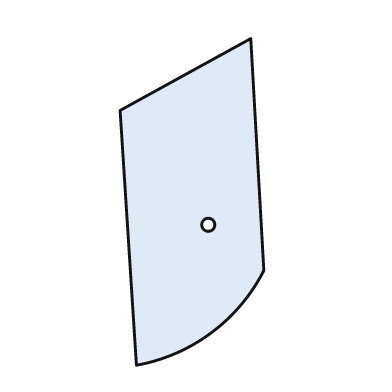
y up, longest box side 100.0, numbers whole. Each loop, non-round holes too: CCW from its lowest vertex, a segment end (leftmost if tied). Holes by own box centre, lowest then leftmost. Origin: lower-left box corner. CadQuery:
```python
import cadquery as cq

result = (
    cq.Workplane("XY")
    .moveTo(5.0, 0.0)
    .threePointArc((28.0, 10.0), (44.0, 29.0))
    .lineTo(40.0, 100.0)
    .lineTo(0.0, 78.0)
    .close()
    .moveTo(27.0, 43.0)
    .circle(2.0)
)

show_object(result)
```